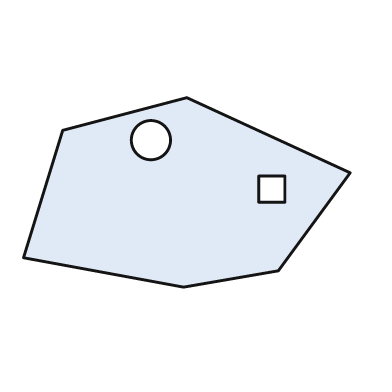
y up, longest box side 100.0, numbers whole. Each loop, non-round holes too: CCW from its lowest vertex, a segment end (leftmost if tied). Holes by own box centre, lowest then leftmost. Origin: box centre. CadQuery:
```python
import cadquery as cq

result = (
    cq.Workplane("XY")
    .moveTo(-1.0, -29.0)
    .lineTo(28.0, -24.0)
    .lineTo(50.0, 6.0)
    .lineTo(0.0, 29.0)
    .lineTo(-38.0, 19.0)
    .lineTo(-50.0, -20.0)
    .close()
    .moveTo(22.0, -3.0)
    .lineTo(30.0, -3.0)
    .lineTo(30.0, 5.0)
    .lineTo(22.0, 5.0)
    .close()
    .moveTo(-11.0, 16.0)
    .circle(6.0)
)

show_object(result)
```